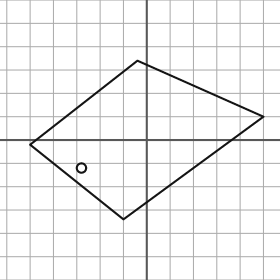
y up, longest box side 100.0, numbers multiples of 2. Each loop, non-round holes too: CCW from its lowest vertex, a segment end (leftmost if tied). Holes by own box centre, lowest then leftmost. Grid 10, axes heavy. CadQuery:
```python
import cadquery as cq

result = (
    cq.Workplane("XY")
    .moveTo(-10.0, -34.0)
    .lineTo(50.0, 10.0)
    .lineTo(-4.0, 34.0)
    .lineTo(-50.0, -2.0)
    .close()
    .moveTo(-28.0, -12.0)
    .circle(2.0)
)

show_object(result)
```